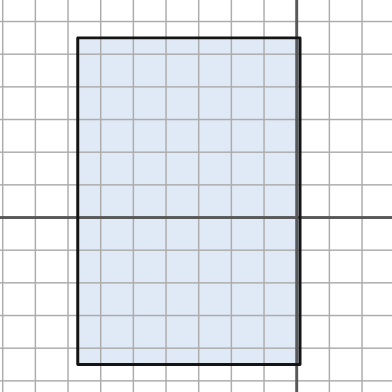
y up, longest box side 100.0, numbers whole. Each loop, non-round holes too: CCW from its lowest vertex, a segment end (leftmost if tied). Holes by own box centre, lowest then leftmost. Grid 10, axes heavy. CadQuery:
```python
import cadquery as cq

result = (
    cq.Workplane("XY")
    .moveTo(-67.0, -45.0)
    .lineTo(1.0, -45.0)
    .lineTo(1.0, 55.0)
    .lineTo(-67.0, 55.0)
    .close()
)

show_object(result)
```